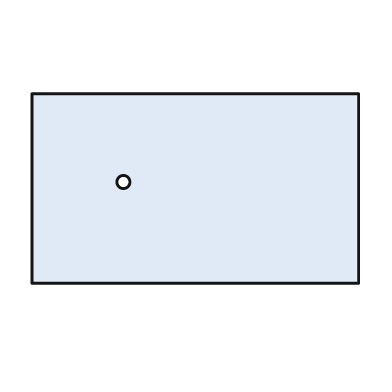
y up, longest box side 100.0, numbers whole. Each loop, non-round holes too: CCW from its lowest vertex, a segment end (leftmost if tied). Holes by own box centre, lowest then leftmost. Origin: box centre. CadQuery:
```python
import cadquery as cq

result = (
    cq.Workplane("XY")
    .moveTo(-50.0, -29.0)
    .lineTo(50.0, -29.0)
    .lineTo(50.0, 29.0)
    .lineTo(-50.0, 29.0)
    .close()
    .moveTo(-22.0, 2.0)
    .circle(2.0)
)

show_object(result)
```